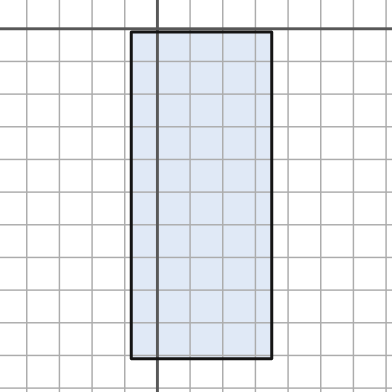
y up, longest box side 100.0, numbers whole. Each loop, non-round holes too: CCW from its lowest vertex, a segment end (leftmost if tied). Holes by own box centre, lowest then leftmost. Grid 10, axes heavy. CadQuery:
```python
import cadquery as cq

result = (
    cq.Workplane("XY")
    .moveTo(-8.0, -101.0)
    .lineTo(35.0, -101.0)
    .lineTo(35.0, -1.0)
    .lineTo(-8.0, -1.0)
    .close()
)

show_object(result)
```